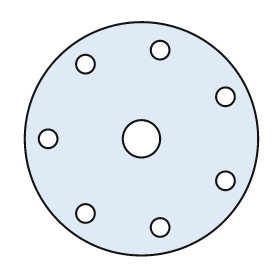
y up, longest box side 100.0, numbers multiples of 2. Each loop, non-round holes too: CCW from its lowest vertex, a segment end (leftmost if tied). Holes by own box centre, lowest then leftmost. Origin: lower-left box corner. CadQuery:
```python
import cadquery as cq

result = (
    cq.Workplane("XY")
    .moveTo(50.0, 50.0)
    .circle(50.0)
    .moveTo(58.0, 12.0)
    .circle(4.0)
    .moveTo(26.0, 18.0)
    .circle(4.0)
    .moveTo(86.0, 32.0)
    .circle(4.0)
    .moveTo(10.0, 50.0)
    .circle(4.0)
    .moveTo(50.0, 50.0)
    .circle(8.0)
    .moveTo(86.0, 68.0)
    .circle(4.0)
    .moveTo(26.0, 82.0)
    .circle(4.0)
    .moveTo(58.0, 88.0)
    .circle(4.0)
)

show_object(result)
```